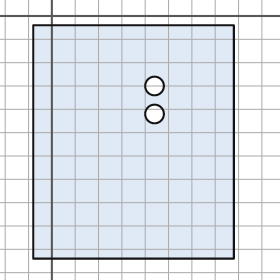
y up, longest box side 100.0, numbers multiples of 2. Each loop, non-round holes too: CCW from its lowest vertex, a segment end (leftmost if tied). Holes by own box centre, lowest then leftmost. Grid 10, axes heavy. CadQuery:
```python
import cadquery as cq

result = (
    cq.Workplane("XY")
    .moveTo(-8.0, -104.0)
    .lineTo(78.0, -104.0)
    .lineTo(78.0, -4.0)
    .lineTo(-8.0, -4.0)
    .close()
    .moveTo(44.0, -42.0)
    .circle(4.0)
    .moveTo(44.0, -30.0)
    .circle(4.0)
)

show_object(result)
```